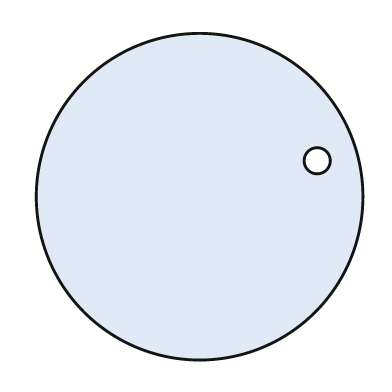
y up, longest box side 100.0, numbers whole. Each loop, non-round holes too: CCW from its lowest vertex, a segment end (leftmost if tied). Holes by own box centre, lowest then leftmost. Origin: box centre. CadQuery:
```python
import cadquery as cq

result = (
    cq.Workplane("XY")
    .moveTo(0.0, 0.0)
    .circle(50.0)
    .moveTo(36.0, 11.0)
    .circle(4.0)
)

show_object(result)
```